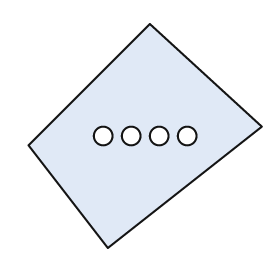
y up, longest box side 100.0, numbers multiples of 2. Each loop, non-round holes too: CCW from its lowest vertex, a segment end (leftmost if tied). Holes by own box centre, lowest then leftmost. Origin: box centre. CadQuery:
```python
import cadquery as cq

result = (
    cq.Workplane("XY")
    .moveTo(-16.0, -48.0)
    .lineTo(50.0, 4.0)
    .lineTo(2.0, 48.0)
    .lineTo(-50.0, -4.0)
    .close()
    .moveTo(-18.0, 0.0)
    .circle(4.0)
    .moveTo(-6.0, 0.0)
    .circle(4.0)
    .moveTo(6.0, 0.0)
    .circle(4.0)
    .moveTo(18.0, 0.0)
    .circle(4.0)
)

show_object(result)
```